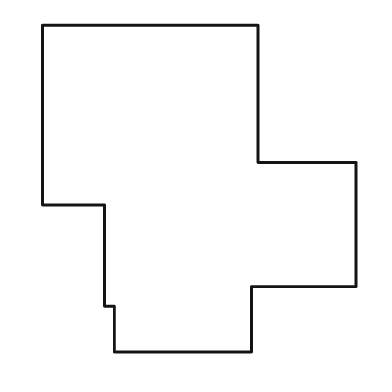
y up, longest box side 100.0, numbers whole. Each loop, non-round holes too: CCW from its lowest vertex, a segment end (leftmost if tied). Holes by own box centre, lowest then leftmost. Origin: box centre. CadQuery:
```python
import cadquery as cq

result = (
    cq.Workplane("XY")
    .moveTo(-26.0, -50.0)
    .lineTo(16.0, -50.0)
    .lineTo(16.0, -30.0)
    .lineTo(48.0, -30.0)
    .lineTo(48.0, 8.0)
    .lineTo(18.0, 8.0)
    .lineTo(18.0, 50.0)
    .lineTo(-48.0, 50.0)
    .lineTo(-48.0, -5.0)
    .lineTo(-29.0, -5.0)
    .lineTo(-29.0, -36.0)
    .lineTo(-26.0, -36.0)
    .close()
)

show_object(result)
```